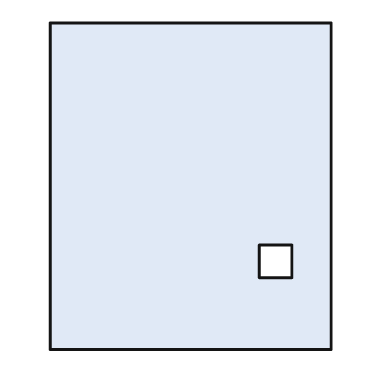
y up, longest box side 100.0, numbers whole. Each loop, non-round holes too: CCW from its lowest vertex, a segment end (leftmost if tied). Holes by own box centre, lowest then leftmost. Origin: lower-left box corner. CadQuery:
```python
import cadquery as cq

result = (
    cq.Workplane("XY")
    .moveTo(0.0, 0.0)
    .lineTo(86.0, 0.0)
    .lineTo(86.0, 100.0)
    .lineTo(0.0, 100.0)
    .close()
    .moveTo(64.0, 22.0)
    .lineTo(74.0, 22.0)
    .lineTo(74.0, 32.0)
    .lineTo(64.0, 32.0)
    .close()
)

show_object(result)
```